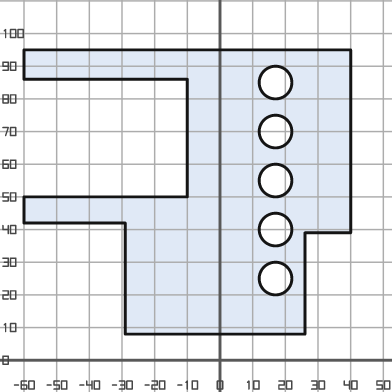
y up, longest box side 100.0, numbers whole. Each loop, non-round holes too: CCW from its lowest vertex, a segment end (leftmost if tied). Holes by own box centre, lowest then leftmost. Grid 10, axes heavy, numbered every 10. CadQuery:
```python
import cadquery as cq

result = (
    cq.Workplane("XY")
    .moveTo(-29.0, 8.0)
    .lineTo(26.0, 8.0)
    .lineTo(26.0, 39.0)
    .lineTo(40.0, 39.0)
    .lineTo(40.0, 95.0)
    .lineTo(-60.0, 95.0)
    .lineTo(-60.0, 86.0)
    .lineTo(-10.0, 86.0)
    .lineTo(-10.0, 50.0)
    .lineTo(-60.0, 50.0)
    .lineTo(-60.0, 42.0)
    .lineTo(-29.0, 42.0)
    .close()
    .moveTo(17.0, 25.0)
    .circle(5.0)
    .moveTo(17.0, 40.0)
    .circle(5.0)
    .moveTo(17.0, 55.0)
    .circle(5.0)
    .moveTo(17.0, 70.0)
    .circle(5.0)
    .moveTo(17.0, 85.0)
    .circle(5.0)
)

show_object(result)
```